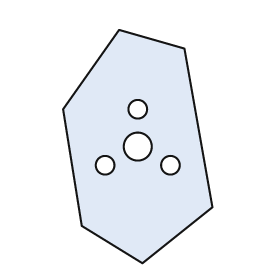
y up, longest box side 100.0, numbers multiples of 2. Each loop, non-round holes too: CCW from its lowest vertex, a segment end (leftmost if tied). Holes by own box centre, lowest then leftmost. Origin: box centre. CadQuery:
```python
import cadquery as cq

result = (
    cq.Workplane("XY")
    .moveTo(2.0, -50.0)
    .lineTo(32.0, -26.0)
    .lineTo(20.0, 42.0)
    .lineTo(-8.0, 50.0)
    .lineTo(-32.0, 16.0)
    .lineTo(-24.0, -34.0)
    .close()
    .moveTo(-14.0, -8.0)
    .circle(4.0)
    .moveTo(14.0, -8.0)
    .circle(4.0)
    .moveTo(0.0, 0.0)
    .circle(6.0)
    .moveTo(0.0, 16.0)
    .circle(4.0)
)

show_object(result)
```